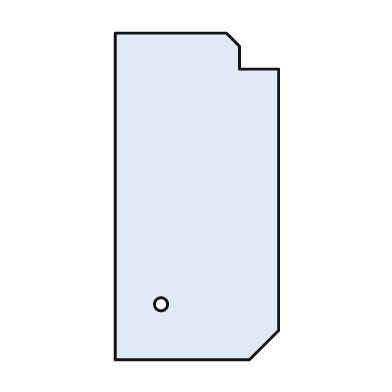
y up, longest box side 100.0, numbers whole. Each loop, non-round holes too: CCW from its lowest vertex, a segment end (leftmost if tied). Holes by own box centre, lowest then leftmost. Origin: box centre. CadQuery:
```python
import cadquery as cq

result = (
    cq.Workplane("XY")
    .moveTo(-25.0, -50.0)
    .lineTo(16.0, -50.0)
    .lineTo(25.0, -41.0)
    .lineTo(25.0, 39.0)
    .lineTo(13.0, 39.0)
    .lineTo(13.0, 46.0)
    .lineTo(9.0, 50.0)
    .lineTo(-25.0, 50.0)
    .close()
    .moveTo(-11.0, -33.0)
    .circle(2.0)
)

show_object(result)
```